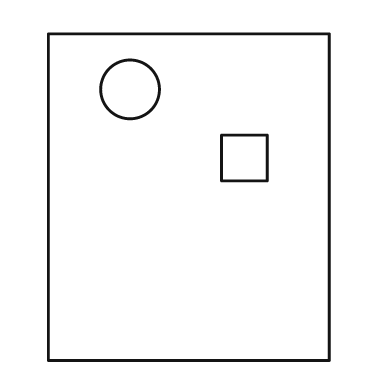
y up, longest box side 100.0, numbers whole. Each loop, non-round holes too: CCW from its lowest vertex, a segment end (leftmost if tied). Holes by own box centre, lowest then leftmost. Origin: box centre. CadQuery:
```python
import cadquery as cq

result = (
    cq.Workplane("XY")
    .moveTo(-43.0, -50.0)
    .lineTo(43.0, -50.0)
    .lineTo(43.0, 50.0)
    .lineTo(-43.0, 50.0)
    .close()
    .moveTo(10.0, 5.0)
    .lineTo(24.0, 5.0)
    .lineTo(24.0, 19.0)
    .lineTo(10.0, 19.0)
    .close()
    .moveTo(-18.0, 33.0)
    .circle(9.0)
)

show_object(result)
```